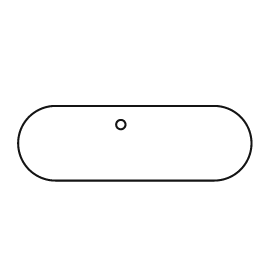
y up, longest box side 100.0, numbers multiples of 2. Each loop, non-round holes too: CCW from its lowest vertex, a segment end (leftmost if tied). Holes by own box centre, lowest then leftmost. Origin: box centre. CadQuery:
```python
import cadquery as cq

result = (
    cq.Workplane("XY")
    .moveTo(-34.0, -16.0)
    .lineTo(34.0, -16.0)
    .threePointArc((50.0, 0.0), (34.0, 16.0))
    .lineTo(-34.0, 16.0)
    .threePointArc((-50.0, 0.0), (-34.0, -16.0))
    .close()
    .moveTo(-6.0, 8.0)
    .circle(2.0)
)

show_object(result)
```